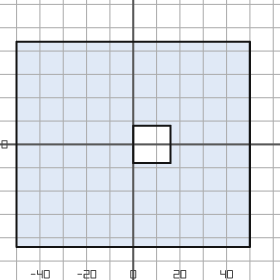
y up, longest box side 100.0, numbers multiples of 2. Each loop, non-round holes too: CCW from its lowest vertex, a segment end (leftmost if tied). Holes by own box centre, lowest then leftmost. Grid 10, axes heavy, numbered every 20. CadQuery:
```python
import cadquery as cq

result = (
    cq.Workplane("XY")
    .moveTo(-50.0, -44.0)
    .lineTo(50.0, -44.0)
    .lineTo(50.0, 44.0)
    .lineTo(-50.0, 44.0)
    .close()
    .moveTo(0.0, -8.0)
    .lineTo(16.0, -8.0)
    .lineTo(16.0, 8.0)
    .lineTo(0.0, 8.0)
    .close()
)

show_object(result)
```